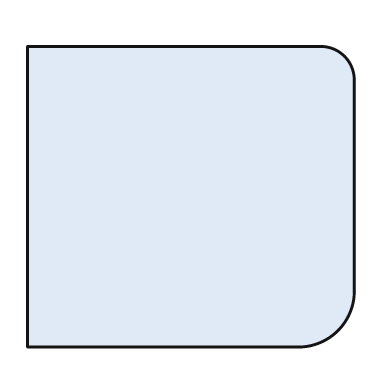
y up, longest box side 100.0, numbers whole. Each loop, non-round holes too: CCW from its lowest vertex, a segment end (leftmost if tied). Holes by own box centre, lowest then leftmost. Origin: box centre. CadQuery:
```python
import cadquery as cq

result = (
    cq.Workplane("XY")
    .moveTo(-50.0, -46.0)
    .lineTo(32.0, -46.0)
    .threePointArc((45.0, -41.0), (50.0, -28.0))
    .lineTo(50.0, 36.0)
    .threePointArc((47.0, 43.0), (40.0, 46.0))
    .lineTo(-50.0, 46.0)
    .close()
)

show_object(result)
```